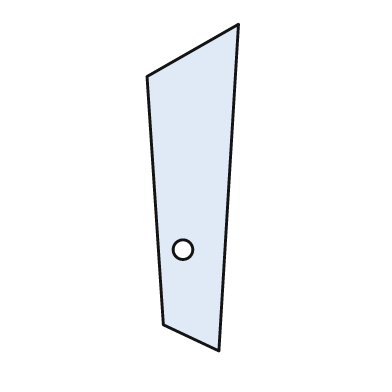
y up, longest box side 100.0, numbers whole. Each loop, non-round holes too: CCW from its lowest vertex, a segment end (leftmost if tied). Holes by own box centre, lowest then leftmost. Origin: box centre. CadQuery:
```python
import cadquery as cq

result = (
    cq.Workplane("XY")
    .moveTo(8.0, -50.0)
    .lineTo(14.0, 50.0)
    .lineTo(-14.0, 34.0)
    .lineTo(-9.0, -42.0)
    .close()
    .moveTo(-3.0, -19.0)
    .circle(3.0)
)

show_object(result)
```